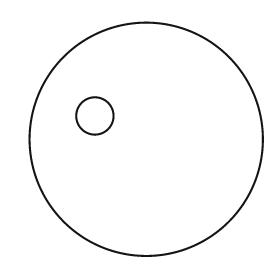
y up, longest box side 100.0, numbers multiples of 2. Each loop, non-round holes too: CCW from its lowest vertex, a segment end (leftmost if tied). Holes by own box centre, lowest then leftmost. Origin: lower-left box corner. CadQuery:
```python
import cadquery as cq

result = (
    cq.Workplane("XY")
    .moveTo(50.0, 50.0)
    .circle(50.0)
    .moveTo(28.0, 60.0)
    .circle(8.0)
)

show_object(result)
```